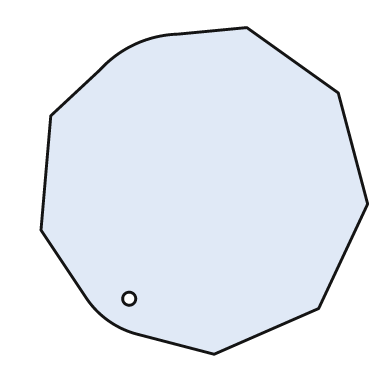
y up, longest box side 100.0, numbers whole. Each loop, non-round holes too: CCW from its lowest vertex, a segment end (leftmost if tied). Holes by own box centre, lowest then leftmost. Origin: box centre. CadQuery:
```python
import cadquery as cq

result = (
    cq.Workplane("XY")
    .moveTo(3.0, -50.0)
    .lineTo(35.0, -36.0)
    .lineTo(50.0, -4.0)
    .lineTo(41.0, 30.0)
    .lineTo(13.0, 50.0)
    .lineTo(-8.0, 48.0)
    .threePointArc((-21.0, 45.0), (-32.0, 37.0))
    .lineTo(-47.0, 23.0)
    .lineTo(-50.0, -12.0)
    .lineTo(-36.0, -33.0)
    .threePointArc((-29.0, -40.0), (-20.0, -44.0))
    .close()
    .moveTo(-23.0, -33.0)
    .circle(2.0)
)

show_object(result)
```